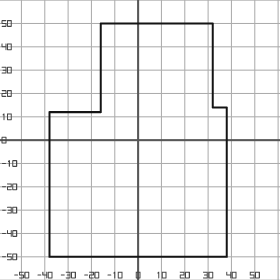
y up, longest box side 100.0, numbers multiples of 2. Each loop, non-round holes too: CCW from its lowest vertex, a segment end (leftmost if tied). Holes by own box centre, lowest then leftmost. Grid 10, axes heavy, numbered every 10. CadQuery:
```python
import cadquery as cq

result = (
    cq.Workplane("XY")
    .moveTo(-38.0, -50.0)
    .lineTo(38.0, -50.0)
    .lineTo(38.0, 14.0)
    .lineTo(32.0, 14.0)
    .lineTo(32.0, 50.0)
    .lineTo(-16.0, 50.0)
    .lineTo(-16.0, 12.0)
    .lineTo(-38.0, 12.0)
    .close()
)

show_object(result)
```